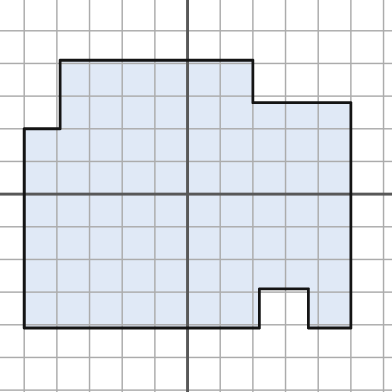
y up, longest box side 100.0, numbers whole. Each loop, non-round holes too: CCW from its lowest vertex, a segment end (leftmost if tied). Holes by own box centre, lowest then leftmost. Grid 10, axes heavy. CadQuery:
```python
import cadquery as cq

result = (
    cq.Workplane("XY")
    .moveTo(-50.0, -41.0)
    .lineTo(22.0, -41.0)
    .lineTo(22.0, -29.0)
    .lineTo(37.0, -29.0)
    .lineTo(37.0, -41.0)
    .lineTo(50.0, -41.0)
    .lineTo(50.0, 28.0)
    .lineTo(20.0, 28.0)
    .lineTo(20.0, 41.0)
    .lineTo(-39.0, 41.0)
    .lineTo(-39.0, 20.0)
    .lineTo(-50.0, 20.0)
    .close()
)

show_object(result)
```